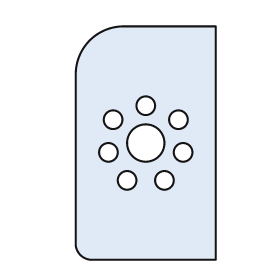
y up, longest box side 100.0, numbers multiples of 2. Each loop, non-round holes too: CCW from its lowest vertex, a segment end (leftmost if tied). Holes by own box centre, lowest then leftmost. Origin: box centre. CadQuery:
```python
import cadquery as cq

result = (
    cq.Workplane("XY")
    .moveTo(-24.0, -50.0)
    .lineTo(30.0, -50.0)
    .lineTo(30.0, 50.0)
    .lineTo(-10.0, 50.0)
    .threePointArc((-24.0, 44.0), (-30.0, 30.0))
    .lineTo(-30.0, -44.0)
    .threePointArc((-28.0, -48.0), (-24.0, -50.0))
    .close()
    .moveTo(-8.0, -16.0)
    .circle(4.0)
    .moveTo(8.0, -16.0)
    .circle(4.0)
    .moveTo(-16.0, -4.0)
    .circle(4.0)
    .moveTo(16.0, -4.0)
    .circle(4.0)
    .moveTo(0.0, 0.0)
    .circle(8.0)
    .moveTo(-14.0, 10.0)
    .circle(4.0)
    .moveTo(14.0, 10.0)
    .circle(4.0)
    .moveTo(0.0, 16.0)
    .circle(4.0)
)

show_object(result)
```